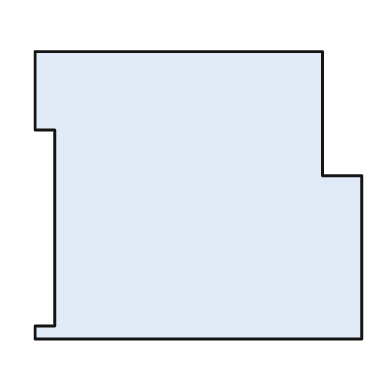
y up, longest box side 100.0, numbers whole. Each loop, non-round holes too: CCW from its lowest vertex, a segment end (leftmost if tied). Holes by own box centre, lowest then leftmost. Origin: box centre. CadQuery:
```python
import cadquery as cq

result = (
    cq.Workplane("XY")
    .moveTo(-50.0, -44.0)
    .lineTo(50.0, -44.0)
    .lineTo(50.0, 6.0)
    .lineTo(38.0, 6.0)
    .lineTo(38.0, 44.0)
    .lineTo(-50.0, 44.0)
    .lineTo(-50.0, 20.0)
    .lineTo(-44.0, 20.0)
    .lineTo(-44.0, -40.0)
    .lineTo(-50.0, -40.0)
    .close()
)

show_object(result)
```